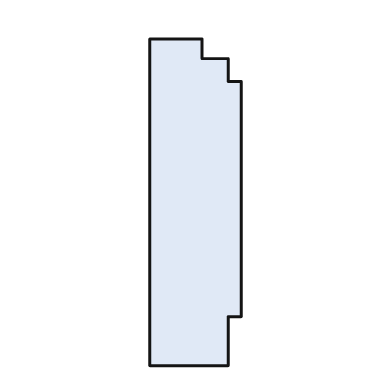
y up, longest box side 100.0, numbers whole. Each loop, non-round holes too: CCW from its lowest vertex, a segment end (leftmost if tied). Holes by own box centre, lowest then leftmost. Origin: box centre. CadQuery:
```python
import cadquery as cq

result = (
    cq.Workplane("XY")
    .moveTo(-14.0, -50.0)
    .lineTo(10.0, -50.0)
    .lineTo(10.0, -35.0)
    .lineTo(14.0, -35.0)
    .lineTo(14.0, 37.0)
    .lineTo(10.0, 37.0)
    .lineTo(10.0, 44.0)
    .lineTo(2.0, 44.0)
    .lineTo(2.0, 50.0)
    .lineTo(-14.0, 50.0)
    .close()
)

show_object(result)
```